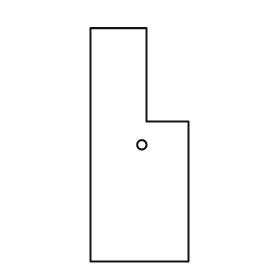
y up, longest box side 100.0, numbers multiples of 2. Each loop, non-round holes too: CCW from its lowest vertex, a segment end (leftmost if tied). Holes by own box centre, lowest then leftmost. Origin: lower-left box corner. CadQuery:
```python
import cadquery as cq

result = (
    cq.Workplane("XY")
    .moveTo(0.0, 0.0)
    .lineTo(42.0, 0.0)
    .lineTo(42.0, 60.0)
    .lineTo(24.0, 60.0)
    .lineTo(24.0, 100.0)
    .lineTo(0.0, 100.0)
    .close()
    .moveTo(22.0, 50.0)
    .circle(2.0)
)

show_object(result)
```